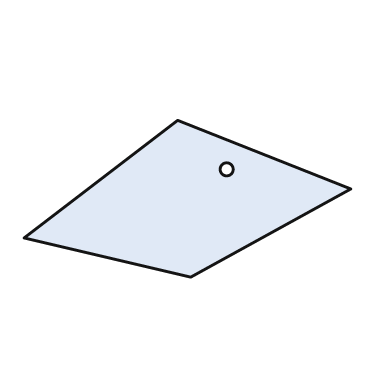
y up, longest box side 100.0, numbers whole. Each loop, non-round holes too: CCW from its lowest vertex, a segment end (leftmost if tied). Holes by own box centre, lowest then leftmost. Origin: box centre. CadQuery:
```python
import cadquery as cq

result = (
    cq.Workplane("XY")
    .moveTo(1.0, -24.0)
    .lineTo(50.0, 3.0)
    .lineTo(-3.0, 24.0)
    .lineTo(-50.0, -12.0)
    .close()
    .moveTo(12.0, 9.0)
    .circle(2.0)
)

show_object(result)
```